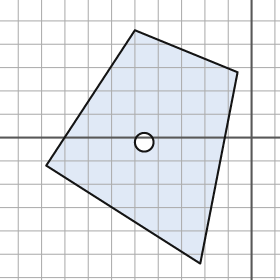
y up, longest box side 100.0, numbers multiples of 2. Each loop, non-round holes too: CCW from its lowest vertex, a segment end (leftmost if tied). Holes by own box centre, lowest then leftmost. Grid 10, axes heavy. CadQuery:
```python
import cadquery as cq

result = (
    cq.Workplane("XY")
    .moveTo(-22.0, -54.0)
    .lineTo(-6.0, 28.0)
    .lineTo(-50.0, 46.0)
    .lineTo(-88.0, -12.0)
    .close()
    .moveTo(-46.0, -2.0)
    .circle(4.0)
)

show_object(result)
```